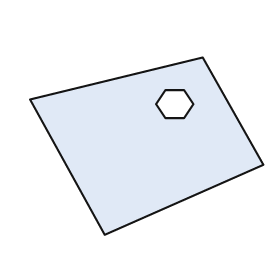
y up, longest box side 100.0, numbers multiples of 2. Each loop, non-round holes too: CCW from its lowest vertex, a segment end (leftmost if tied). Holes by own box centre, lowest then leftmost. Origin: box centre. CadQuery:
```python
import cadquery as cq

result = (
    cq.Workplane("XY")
    .moveTo(-18.0, -38.0)
    .lineTo(50.0, -8.0)
    .lineTo(24.0, 38.0)
    .lineTo(-50.0, 20.0)
    .close()
    .moveTo(8.0, 12.0)
    .lineTo(16.0, 12.0)
    .lineTo(20.0, 18.0)
    .lineTo(16.0, 24.0)
    .lineTo(8.0, 24.0)
    .lineTo(4.0, 18.0)
    .close()
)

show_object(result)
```